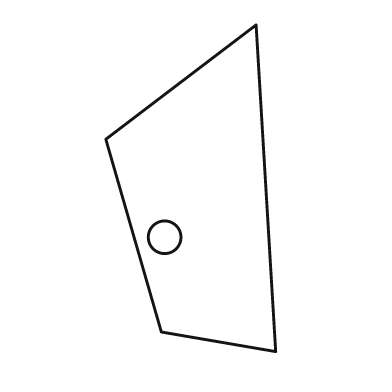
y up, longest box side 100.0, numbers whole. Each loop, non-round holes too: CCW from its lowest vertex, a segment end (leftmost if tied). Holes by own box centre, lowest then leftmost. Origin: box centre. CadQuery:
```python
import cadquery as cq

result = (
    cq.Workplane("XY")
    .moveTo(26.0, -50.0)
    .lineTo(20.0, 50.0)
    .lineTo(-26.0, 15.0)
    .lineTo(-9.0, -44.0)
    .close()
    .moveTo(-8.0, -15.0)
    .circle(5.0)
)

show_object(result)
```